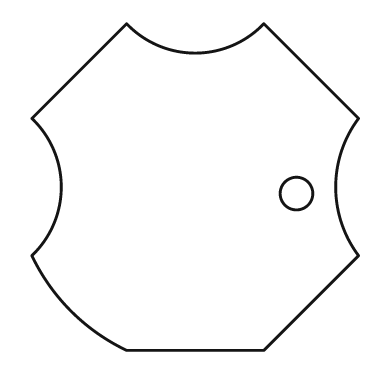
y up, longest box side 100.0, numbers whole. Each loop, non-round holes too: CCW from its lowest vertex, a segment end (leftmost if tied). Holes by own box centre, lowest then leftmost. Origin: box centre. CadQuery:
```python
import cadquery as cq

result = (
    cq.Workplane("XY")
    .moveTo(-21.0, -50.0)
    .lineTo(21.0, -50.0)
    .lineTo(50.0, -21.0)
    .threePointArc((43.0, 0.0), (50.0, 21.0))
    .lineTo(21.0, 50.0)
    .threePointArc((0.0, 41.0), (-21.0, 50.0))
    .lineTo(-50.0, 21.0)
    .threePointArc((-41.0, 0.0), (-50.0, -21.0))
    .threePointArc((-38.0, -38.0), (-21.0, -50.0))
    .close()
    .moveTo(31.0, -2.0)
    .circle(5.0)
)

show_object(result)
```